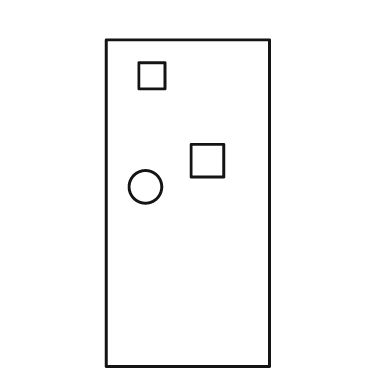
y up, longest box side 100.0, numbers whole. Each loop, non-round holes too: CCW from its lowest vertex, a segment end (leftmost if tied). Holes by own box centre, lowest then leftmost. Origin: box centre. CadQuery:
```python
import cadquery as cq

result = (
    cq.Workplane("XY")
    .moveTo(-25.0, -50.0)
    .lineTo(25.0, -50.0)
    .lineTo(25.0, 50.0)
    .lineTo(-25.0, 50.0)
    .close()
    .moveTo(-13.0, 5.0)
    .circle(5.0)
    .moveTo(1.0, 8.0)
    .lineTo(11.0, 8.0)
    .lineTo(11.0, 18.0)
    .lineTo(1.0, 18.0)
    .close()
    .moveTo(-15.0, 35.0)
    .lineTo(-7.0, 35.0)
    .lineTo(-7.0, 43.0)
    .lineTo(-15.0, 43.0)
    .close()
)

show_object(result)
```